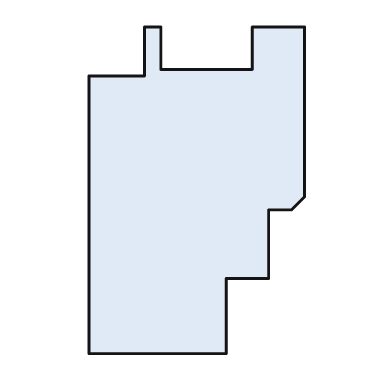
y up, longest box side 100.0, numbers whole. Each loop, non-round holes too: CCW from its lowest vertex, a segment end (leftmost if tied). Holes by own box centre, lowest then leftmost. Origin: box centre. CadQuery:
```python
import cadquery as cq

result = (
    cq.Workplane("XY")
    .moveTo(-33.0, -50.0)
    .lineTo(9.0, -50.0)
    .lineTo(9.0, -27.0)
    .lineTo(22.0, -27.0)
    .lineTo(22.0, -6.0)
    .lineTo(29.0, -6.0)
    .lineTo(33.0, -2.0)
    .lineTo(33.0, 50.0)
    .lineTo(17.0, 50.0)
    .lineTo(17.0, 37.0)
    .lineTo(-11.0, 37.0)
    .lineTo(-11.0, 50.0)
    .lineTo(-16.0, 50.0)
    .lineTo(-16.0, 35.0)
    .lineTo(-33.0, 35.0)
    .close()
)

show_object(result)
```